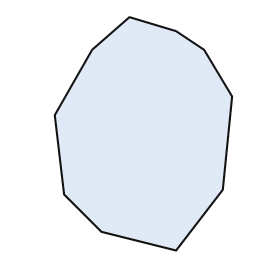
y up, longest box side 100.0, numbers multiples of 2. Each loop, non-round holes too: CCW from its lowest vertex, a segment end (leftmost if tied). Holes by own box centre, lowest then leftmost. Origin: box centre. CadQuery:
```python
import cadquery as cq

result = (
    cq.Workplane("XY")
    .moveTo(14.0, -50.0)
    .lineTo(34.0, -24.0)
    .lineTo(38.0, 16.0)
    .lineTo(26.0, 36.0)
    .lineTo(14.0, 44.0)
    .lineTo(-6.0, 50.0)
    .lineTo(-22.0, 36.0)
    .lineTo(-38.0, 8.0)
    .lineTo(-34.0, -26.0)
    .lineTo(-18.0, -42.0)
    .close()
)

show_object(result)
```